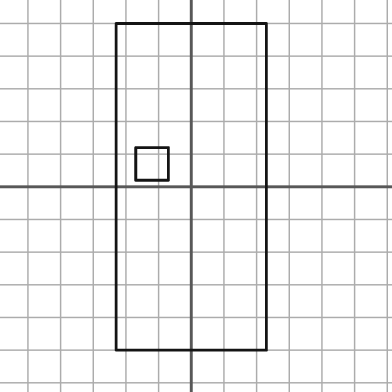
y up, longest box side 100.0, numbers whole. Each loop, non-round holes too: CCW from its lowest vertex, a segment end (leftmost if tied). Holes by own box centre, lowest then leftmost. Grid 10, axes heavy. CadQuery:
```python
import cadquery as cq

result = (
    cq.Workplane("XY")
    .moveTo(-23.0, -50.0)
    .lineTo(23.0, -50.0)
    .lineTo(23.0, 50.0)
    .lineTo(-23.0, 50.0)
    .close()
    .moveTo(-17.0, 2.0)
    .lineTo(-7.0, 2.0)
    .lineTo(-7.0, 12.0)
    .lineTo(-17.0, 12.0)
    .close()
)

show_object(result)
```